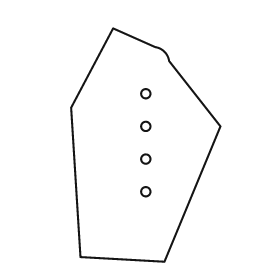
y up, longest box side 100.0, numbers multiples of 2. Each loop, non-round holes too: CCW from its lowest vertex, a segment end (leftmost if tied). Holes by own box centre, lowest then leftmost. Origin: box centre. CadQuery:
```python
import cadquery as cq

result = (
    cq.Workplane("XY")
    .moveTo(8.0, -50.0)
    .lineTo(32.0, 8.0)
    .lineTo(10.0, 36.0)
    .threePointArc((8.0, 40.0), (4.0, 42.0))
    .lineTo(-14.0, 50.0)
    .lineTo(-32.0, 16.0)
    .lineTo(-28.0, -48.0)
    .close()
    .moveTo(0.0, -20.0)
    .circle(2.0)
    .moveTo(0.0, -6.0)
    .circle(2.0)
    .moveTo(0.0, 8.0)
    .circle(2.0)
    .moveTo(0.0, 22.0)
    .circle(2.0)
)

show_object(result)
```